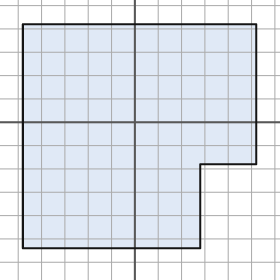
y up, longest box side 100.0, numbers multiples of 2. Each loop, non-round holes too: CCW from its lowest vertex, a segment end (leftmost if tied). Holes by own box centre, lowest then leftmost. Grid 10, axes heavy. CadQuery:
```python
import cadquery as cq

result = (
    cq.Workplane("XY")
    .moveTo(-48.0, -54.0)
    .lineTo(28.0, -54.0)
    .lineTo(28.0, -18.0)
    .lineTo(52.0, -18.0)
    .lineTo(52.0, 42.0)
    .lineTo(-48.0, 42.0)
    .close()
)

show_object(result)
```